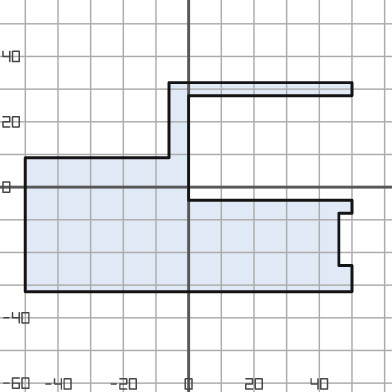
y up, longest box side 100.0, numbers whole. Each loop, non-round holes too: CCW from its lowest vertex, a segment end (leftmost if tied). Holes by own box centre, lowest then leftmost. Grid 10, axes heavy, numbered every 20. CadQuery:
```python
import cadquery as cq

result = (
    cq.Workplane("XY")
    .moveTo(-50.0, -32.0)
    .lineTo(50.0, -32.0)
    .lineTo(50.0, -24.0)
    .lineTo(46.0, -24.0)
    .lineTo(46.0, -8.0)
    .lineTo(50.0, -8.0)
    .lineTo(50.0, -4.0)
    .lineTo(0.0, -4.0)
    .lineTo(0.0, 28.0)
    .lineTo(50.0, 28.0)
    .lineTo(50.0, 32.0)
    .lineTo(-6.0, 32.0)
    .lineTo(-6.0, 9.0)
    .lineTo(-50.0, 9.0)
    .close()
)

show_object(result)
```